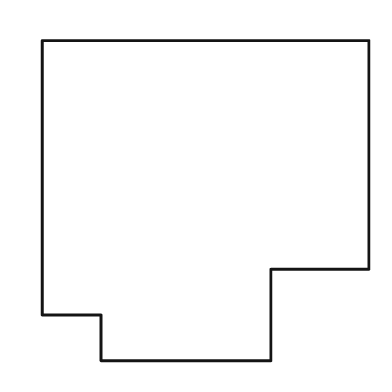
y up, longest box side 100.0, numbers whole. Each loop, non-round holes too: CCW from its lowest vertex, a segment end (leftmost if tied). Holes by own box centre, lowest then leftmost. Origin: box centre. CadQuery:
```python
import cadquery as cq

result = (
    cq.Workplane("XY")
    .moveTo(-32.0, -49.0)
    .lineTo(20.0, -49.0)
    .lineTo(20.0, -21.0)
    .lineTo(50.0, -21.0)
    .lineTo(50.0, 49.0)
    .lineTo(-50.0, 49.0)
    .lineTo(-50.0, -35.0)
    .lineTo(-32.0, -35.0)
    .close()
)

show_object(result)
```